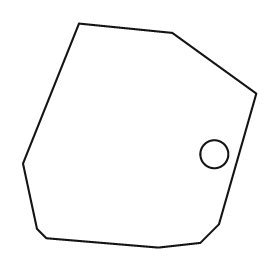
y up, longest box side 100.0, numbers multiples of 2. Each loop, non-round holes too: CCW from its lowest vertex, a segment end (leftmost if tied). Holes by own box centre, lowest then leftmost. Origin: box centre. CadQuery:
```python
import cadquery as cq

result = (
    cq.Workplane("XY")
    .moveTo(8.0, -48.0)
    .lineTo(26.0, -46.0)
    .lineTo(34.0, -38.0)
    .lineTo(50.0, 18.0)
    .lineTo(14.0, 44.0)
    .lineTo(-26.0, 48.0)
    .lineTo(-50.0, -12.0)
    .lineTo(-44.0, -40.0)
    .lineTo(-40.0, -44.0)
    .close()
    .moveTo(32.0, -8.0)
    .circle(6.0)
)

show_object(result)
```